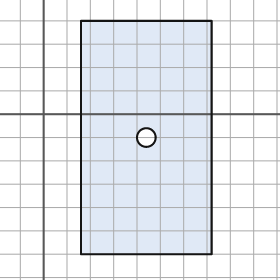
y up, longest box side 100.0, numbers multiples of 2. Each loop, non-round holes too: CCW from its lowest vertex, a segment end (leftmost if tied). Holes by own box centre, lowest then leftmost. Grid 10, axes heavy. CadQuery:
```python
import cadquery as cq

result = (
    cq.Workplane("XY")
    .moveTo(16.0, -60.0)
    .lineTo(72.0, -60.0)
    .lineTo(72.0, 40.0)
    .lineTo(16.0, 40.0)
    .close()
    .moveTo(44.0, -10.0)
    .circle(4.0)
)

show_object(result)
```